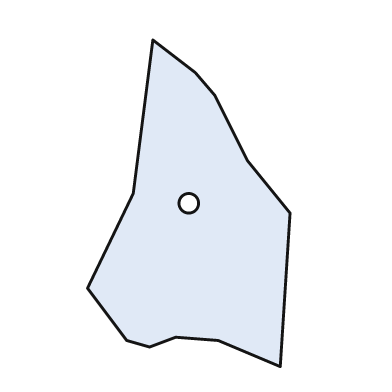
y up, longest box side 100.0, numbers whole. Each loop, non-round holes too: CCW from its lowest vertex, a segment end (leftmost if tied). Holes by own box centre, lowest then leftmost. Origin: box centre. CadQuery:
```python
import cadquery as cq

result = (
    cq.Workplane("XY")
    .moveTo(28.0, -50.0)
    .lineTo(31.0, -3.0)
    .lineTo(18.0, 13.0)
    .lineTo(8.0, 33.0)
    .lineTo(2.0, 40.0)
    .lineTo(-11.0, 50.0)
    .lineTo(-17.0, 3.0)
    .lineTo(-31.0, -26.0)
    .lineTo(-19.0, -42.0)
    .lineTo(-12.0, -44.0)
    .lineTo(-4.0, -41.0)
    .lineTo(9.0, -42.0)
    .close()
    .moveTo(0.0, 0.0)
    .circle(3.0)
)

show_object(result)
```